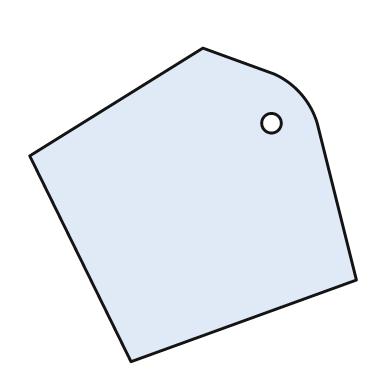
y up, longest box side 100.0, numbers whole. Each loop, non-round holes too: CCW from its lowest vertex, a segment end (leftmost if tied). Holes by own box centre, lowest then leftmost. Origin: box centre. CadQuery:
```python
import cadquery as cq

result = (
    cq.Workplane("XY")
    .moveTo(-19.0, -48.0)
    .lineTo(50.0, -23.0)
    .lineTo(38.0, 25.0)
    .threePointArc((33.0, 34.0), (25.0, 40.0))
    .lineTo(3.0, 48.0)
    .lineTo(-50.0, 15.0)
    .close()
    .moveTo(24.0, 25.0)
    .circle(3.0)
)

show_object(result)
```